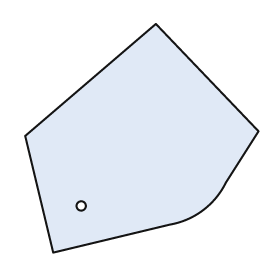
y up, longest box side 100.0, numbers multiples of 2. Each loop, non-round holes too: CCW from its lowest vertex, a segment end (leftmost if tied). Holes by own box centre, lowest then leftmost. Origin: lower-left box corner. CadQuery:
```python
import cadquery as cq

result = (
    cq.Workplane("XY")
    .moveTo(12.0, 0.0)
    .lineTo(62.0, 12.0)
    .threePointArc((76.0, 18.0), (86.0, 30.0))
    .lineTo(100.0, 52.0)
    .lineTo(56.0, 98.0)
    .lineTo(0.0, 50.0)
    .close()
    .moveTo(24.0, 20.0)
    .circle(2.0)
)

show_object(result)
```